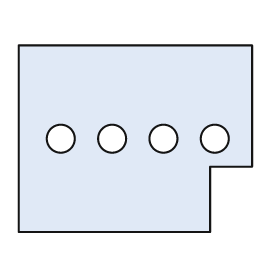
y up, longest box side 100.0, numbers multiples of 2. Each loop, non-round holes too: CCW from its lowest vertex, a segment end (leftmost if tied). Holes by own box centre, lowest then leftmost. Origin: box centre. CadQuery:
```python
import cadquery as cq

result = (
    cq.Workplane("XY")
    .moveTo(-50.0, -40.0)
    .lineTo(32.0, -40.0)
    .lineTo(32.0, -12.0)
    .lineTo(50.0, -12.0)
    .lineTo(50.0, 40.0)
    .lineTo(-50.0, 40.0)
    .close()
    .moveTo(-32.0, 0.0)
    .circle(6.0)
    .moveTo(-10.0, 0.0)
    .circle(6.0)
    .moveTo(12.0, 0.0)
    .circle(6.0)
    .moveTo(34.0, 0.0)
    .circle(6.0)
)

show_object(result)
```